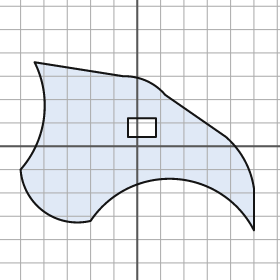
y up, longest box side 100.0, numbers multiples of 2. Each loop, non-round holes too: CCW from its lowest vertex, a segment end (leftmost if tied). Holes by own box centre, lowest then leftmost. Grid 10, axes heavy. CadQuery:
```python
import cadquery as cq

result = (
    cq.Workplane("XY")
    .moveTo(50.0, -36.0)
    .lineTo(50.0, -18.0)
    .threePointArc((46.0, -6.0), (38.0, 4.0))
    .lineTo(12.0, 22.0)
    .threePointArc((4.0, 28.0), (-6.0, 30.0))
    .lineTo(-44.0, 36.0)
    .threePointArc((-40.0, 12.0), (-50.0, -10.0))
    .threePointArc((-40.0, -28.0), (-20.0, -32.0))
    .threePointArc((16.0, -14.0), (50.0, -36.0))
    .close()
    .moveTo(-4.0, 4.0)
    .lineTo(8.0, 4.0)
    .lineTo(8.0, 12.0)
    .lineTo(-4.0, 12.0)
    .close()
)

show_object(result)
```